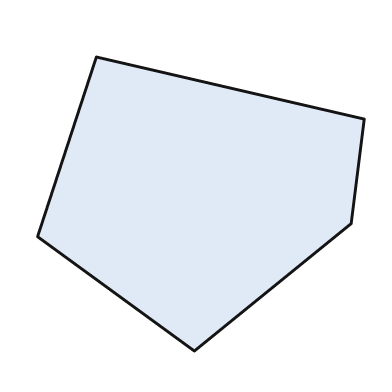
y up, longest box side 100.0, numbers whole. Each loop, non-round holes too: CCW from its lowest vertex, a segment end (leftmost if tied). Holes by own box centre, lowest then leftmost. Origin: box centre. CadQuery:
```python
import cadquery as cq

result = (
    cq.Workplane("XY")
    .moveTo(-2.0, -45.0)
    .lineTo(46.0, -6.0)
    .lineTo(50.0, 26.0)
    .lineTo(-32.0, 45.0)
    .lineTo(-50.0, -10.0)
    .close()
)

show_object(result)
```